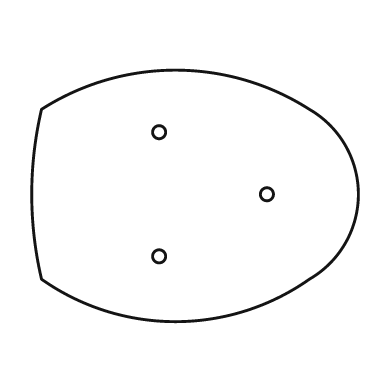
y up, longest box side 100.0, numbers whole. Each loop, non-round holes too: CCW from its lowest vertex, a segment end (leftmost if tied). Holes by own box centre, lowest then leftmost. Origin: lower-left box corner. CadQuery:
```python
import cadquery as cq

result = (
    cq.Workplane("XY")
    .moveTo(3.0, 13.0)
    .threePointArc((44.0, 0.0), (85.0, 13.0))
    .threePointArc((100.0, 39.0), (85.0, 65.0))
    .threePointArc((44.0, 77.0), (3.0, 65.0))
    .threePointArc((0.0, 39.0), (3.0, 13.0))
    .close()
    .moveTo(39.0, 20.0)
    .circle(2.0)
    .moveTo(72.0, 39.0)
    .circle(2.0)
    .moveTo(39.0, 58.0)
    .circle(2.0)
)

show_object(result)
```